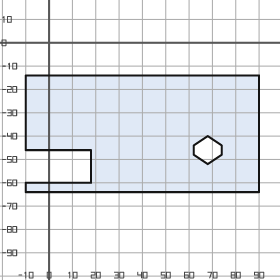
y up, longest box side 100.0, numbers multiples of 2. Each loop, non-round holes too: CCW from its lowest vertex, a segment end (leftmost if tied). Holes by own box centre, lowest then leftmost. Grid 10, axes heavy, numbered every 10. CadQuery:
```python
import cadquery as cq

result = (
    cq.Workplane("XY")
    .moveTo(-10.0, -64.0)
    .lineTo(90.0, -64.0)
    .lineTo(90.0, -14.0)
    .lineTo(-10.0, -14.0)
    .lineTo(-10.0, -46.0)
    .lineTo(18.0, -46.0)
    .lineTo(18.0, -60.0)
    .lineTo(-10.0, -60.0)
    .close()
    .moveTo(68.0, -52.0)
    .lineTo(74.0, -48.0)
    .lineTo(74.0, -44.0)
    .lineTo(68.0, -40.0)
    .lineTo(62.0, -44.0)
    .lineTo(62.0, -48.0)
    .close()
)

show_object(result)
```